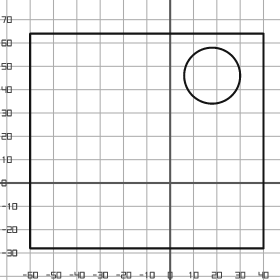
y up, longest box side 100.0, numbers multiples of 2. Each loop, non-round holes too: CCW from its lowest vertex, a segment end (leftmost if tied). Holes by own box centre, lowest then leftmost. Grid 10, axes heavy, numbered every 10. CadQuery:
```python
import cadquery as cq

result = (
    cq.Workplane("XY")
    .moveTo(-60.0, -28.0)
    .lineTo(40.0, -28.0)
    .lineTo(40.0, 64.0)
    .lineTo(-60.0, 64.0)
    .close()
    .moveTo(18.0, 46.0)
    .circle(12.0)
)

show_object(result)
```